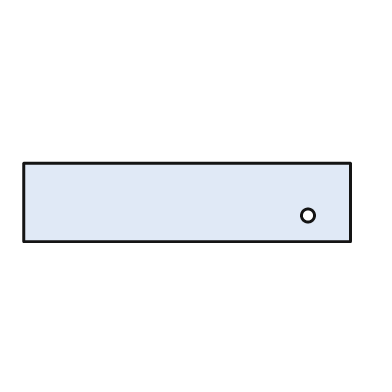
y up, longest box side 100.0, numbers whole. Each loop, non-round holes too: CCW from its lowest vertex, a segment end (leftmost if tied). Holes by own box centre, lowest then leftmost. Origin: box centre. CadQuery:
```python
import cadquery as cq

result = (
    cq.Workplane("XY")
    .moveTo(-50.0, -12.0)
    .lineTo(50.0, -12.0)
    .lineTo(50.0, 12.0)
    .lineTo(-50.0, 12.0)
    .close()
    .moveTo(37.0, -4.0)
    .circle(2.0)
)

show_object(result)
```